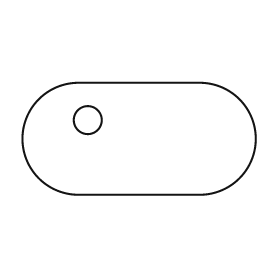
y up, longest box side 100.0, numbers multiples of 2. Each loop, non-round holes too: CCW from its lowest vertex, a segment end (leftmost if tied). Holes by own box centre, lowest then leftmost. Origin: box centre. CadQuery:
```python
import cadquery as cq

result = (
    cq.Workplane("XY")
    .moveTo(-26.0, -24.0)
    .lineTo(26.0, -24.0)
    .threePointArc((50.0, 0.0), (26.0, 24.0))
    .lineTo(-26.0, 24.0)
    .threePointArc((-50.0, 0.0), (-26.0, -24.0))
    .close()
    .moveTo(-22.0, 8.0)
    .circle(6.0)
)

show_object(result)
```